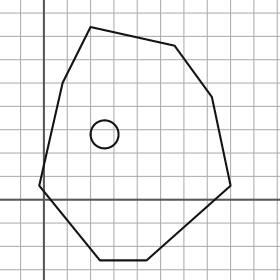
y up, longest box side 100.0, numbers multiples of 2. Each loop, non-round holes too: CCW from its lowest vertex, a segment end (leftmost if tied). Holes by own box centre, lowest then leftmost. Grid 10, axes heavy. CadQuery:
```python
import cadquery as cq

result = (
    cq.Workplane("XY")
    .moveTo(24.0, -26.0)
    .lineTo(44.0, -26.0)
    .lineTo(80.0, 6.0)
    .lineTo(72.0, 44.0)
    .lineTo(56.0, 66.0)
    .lineTo(20.0, 74.0)
    .lineTo(8.0, 50.0)
    .lineTo(-2.0, 6.0)
    .close()
    .moveTo(26.0, 28.0)
    .circle(6.0)
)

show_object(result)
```